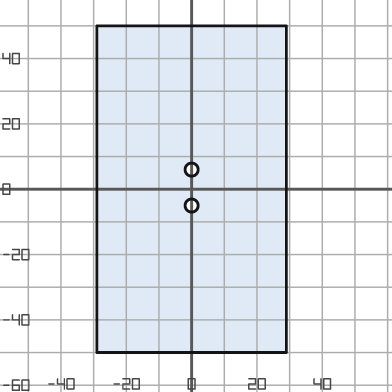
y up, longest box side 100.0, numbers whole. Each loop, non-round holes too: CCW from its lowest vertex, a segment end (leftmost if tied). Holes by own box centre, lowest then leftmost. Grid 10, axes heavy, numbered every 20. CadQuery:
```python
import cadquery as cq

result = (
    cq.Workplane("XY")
    .moveTo(-29.0, -50.0)
    .lineTo(29.0, -50.0)
    .lineTo(29.0, 50.0)
    .lineTo(-29.0, 50.0)
    .close()
    .moveTo(0.0, -5.0)
    .circle(2.0)
    .moveTo(0.0, 6.0)
    .circle(2.0)
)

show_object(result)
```